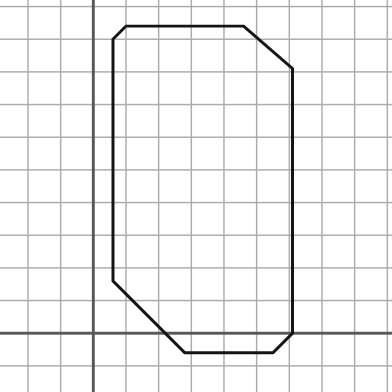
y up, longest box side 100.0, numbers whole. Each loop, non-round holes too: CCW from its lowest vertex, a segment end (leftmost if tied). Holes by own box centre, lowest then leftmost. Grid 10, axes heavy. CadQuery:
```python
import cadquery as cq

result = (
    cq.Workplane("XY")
    .moveTo(28.0, -6.0)
    .lineTo(55.0, -6.0)
    .lineTo(61.0, 0.0)
    .lineTo(61.0, 81.0)
    .lineTo(46.0, 94.0)
    .lineTo(10.0, 94.0)
    .lineTo(6.0, 90.0)
    .lineTo(6.0, 16.0)
    .close()
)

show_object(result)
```